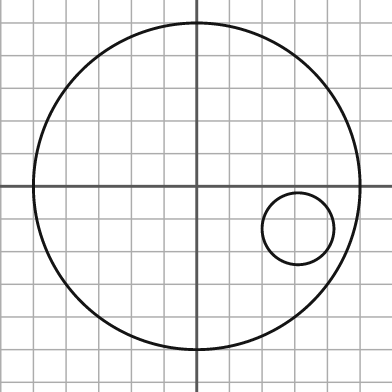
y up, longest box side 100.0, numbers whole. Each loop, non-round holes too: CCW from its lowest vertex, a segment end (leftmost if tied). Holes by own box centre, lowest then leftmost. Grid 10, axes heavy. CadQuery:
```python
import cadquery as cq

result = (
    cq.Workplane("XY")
    .moveTo(0.0, 0.0)
    .circle(50.0)
    .moveTo(31.0, -13.0)
    .circle(11.0)
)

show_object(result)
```